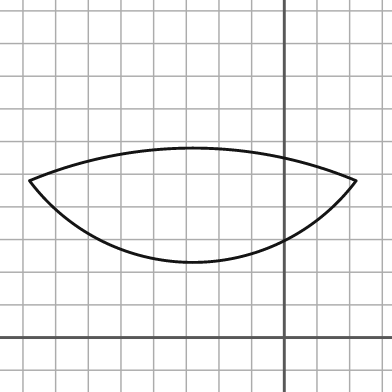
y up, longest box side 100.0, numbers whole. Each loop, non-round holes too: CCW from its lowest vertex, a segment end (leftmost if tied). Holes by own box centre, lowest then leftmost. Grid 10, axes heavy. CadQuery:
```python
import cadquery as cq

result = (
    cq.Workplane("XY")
    .moveTo(-78.0, 48.0)
    .threePointArc((-28.0, 23.0), (22.0, 48.0))
    .threePointArc((-28.0, 58.0), (-78.0, 48.0))
    .close()
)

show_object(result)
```